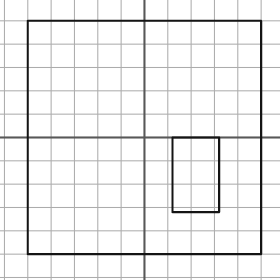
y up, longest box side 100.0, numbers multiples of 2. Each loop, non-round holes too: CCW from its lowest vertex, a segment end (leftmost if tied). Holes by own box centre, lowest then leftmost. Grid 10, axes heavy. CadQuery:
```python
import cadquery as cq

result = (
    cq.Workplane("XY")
    .moveTo(-50.0, -50.0)
    .lineTo(50.0, -50.0)
    .lineTo(50.0, 50.0)
    .lineTo(-50.0, 50.0)
    .close()
    .moveTo(12.0, -32.0)
    .lineTo(32.0, -32.0)
    .lineTo(32.0, 0.0)
    .lineTo(12.0, 0.0)
    .close()
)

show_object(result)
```